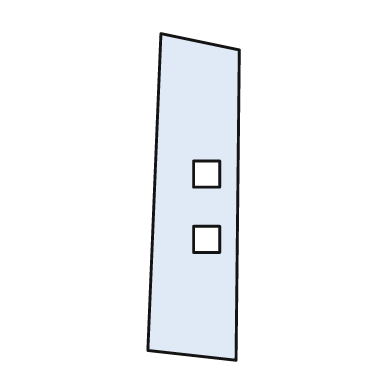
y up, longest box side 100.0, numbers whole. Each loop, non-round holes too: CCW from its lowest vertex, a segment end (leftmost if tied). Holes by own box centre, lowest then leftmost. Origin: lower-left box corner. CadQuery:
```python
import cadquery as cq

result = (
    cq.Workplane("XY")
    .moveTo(27.0, 0.0)
    .lineTo(28.0, 95.0)
    .lineTo(4.0, 100.0)
    .lineTo(0.0, 3.0)
    .close()
    .moveTo(14.0, 33.0)
    .lineTo(22.0, 33.0)
    .lineTo(22.0, 41.0)
    .lineTo(14.0, 41.0)
    .close()
    .moveTo(14.0, 53.0)
    .lineTo(22.0, 53.0)
    .lineTo(22.0, 61.0)
    .lineTo(14.0, 61.0)
    .close()
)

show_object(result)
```